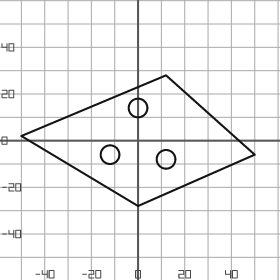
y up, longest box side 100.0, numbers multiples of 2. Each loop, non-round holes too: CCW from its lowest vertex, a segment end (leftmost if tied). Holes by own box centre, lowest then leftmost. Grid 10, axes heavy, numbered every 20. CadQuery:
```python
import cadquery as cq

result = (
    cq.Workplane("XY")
    .moveTo(0.0, -28.0)
    .lineTo(50.0, -6.0)
    .lineTo(12.0, 28.0)
    .lineTo(-50.0, 2.0)
    .close()
    .moveTo(12.0, -8.0)
    .circle(4.0)
    .moveTo(-12.0, -6.0)
    .circle(4.0)
    .moveTo(0.0, 14.0)
    .circle(4.0)
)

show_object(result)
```